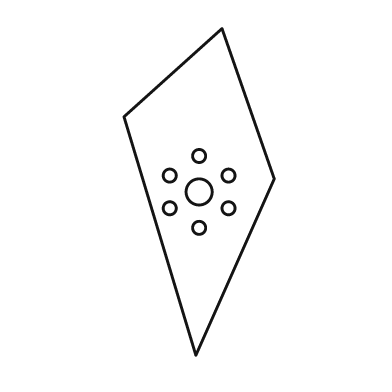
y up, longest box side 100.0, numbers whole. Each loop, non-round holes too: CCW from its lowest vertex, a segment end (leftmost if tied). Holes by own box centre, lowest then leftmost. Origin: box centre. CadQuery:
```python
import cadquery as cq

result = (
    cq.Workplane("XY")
    .moveTo(-1.0, -50.0)
    .lineTo(23.0, 4.0)
    .lineTo(7.0, 50.0)
    .lineTo(-23.0, 23.0)
    .close()
    .moveTo(0.0, -11.0)
    .circle(2.0)
    .moveTo(-9.0, -5.0)
    .circle(2.0)
    .moveTo(9.0, -5.0)
    .circle(2.0)
    .moveTo(0.0, 0.0)
    .circle(4.0)
    .moveTo(-9.0, 5.0)
    .circle(2.0)
    .moveTo(9.0, 5.0)
    .circle(2.0)
    .moveTo(0.0, 11.0)
    .circle(2.0)
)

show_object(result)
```